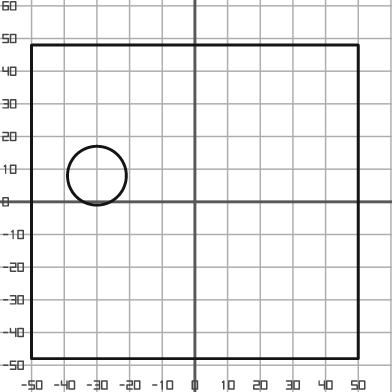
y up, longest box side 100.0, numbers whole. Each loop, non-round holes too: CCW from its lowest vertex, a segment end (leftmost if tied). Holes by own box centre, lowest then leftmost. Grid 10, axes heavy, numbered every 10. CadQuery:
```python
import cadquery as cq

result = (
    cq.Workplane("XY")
    .moveTo(-50.0, -48.0)
    .lineTo(50.0, -48.0)
    .lineTo(50.0, 48.0)
    .lineTo(-50.0, 48.0)
    .close()
    .moveTo(-30.0, 8.0)
    .circle(9.0)
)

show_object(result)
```